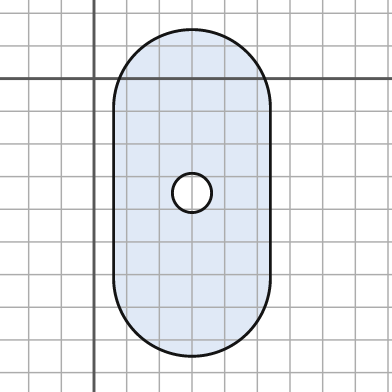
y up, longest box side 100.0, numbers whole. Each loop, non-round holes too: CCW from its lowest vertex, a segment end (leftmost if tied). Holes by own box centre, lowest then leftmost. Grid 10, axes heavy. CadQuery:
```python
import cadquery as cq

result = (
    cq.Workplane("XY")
    .moveTo(6.0, -61.0)
    .threePointArc((30.0, -85.0), (54.0, -61.0))
    .lineTo(54.0, -9.0)
    .threePointArc((30.0, 15.0), (6.0, -9.0))
    .close()
    .moveTo(30.0, -35.0)
    .circle(6.0)
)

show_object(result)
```